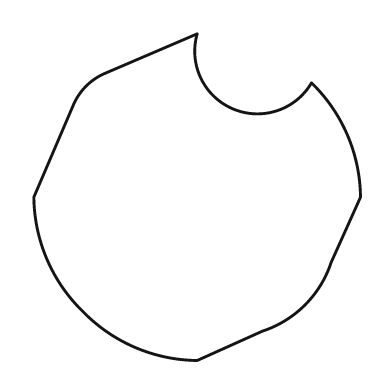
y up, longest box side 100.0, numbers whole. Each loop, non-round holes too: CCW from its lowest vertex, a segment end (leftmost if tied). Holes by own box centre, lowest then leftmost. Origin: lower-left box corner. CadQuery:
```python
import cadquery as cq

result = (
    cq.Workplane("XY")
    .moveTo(50.0, 0.0)
    .lineTo(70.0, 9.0)
    .threePointArc((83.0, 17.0), (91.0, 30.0))
    .lineTo(100.0, 50.0)
    .threePointArc((96.0, 69.0), (85.0, 85.0))
    .threePointArc((61.0, 77.0), (50.0, 100.0))
    .lineTo(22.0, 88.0)
    .threePointArc((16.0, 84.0), (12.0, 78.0))
    .lineTo(0.0, 50.0)
    .threePointArc((4.0, 31.0), (15.0, 15.0))
    .threePointArc((31.0, 4.0), (50.0, 0.0))
    .close()
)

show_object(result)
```